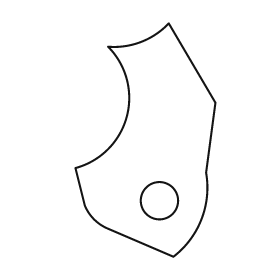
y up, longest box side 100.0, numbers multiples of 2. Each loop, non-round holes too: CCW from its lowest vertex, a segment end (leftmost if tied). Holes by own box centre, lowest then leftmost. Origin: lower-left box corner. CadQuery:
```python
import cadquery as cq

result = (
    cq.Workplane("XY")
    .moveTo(42.0, 0.0)
    .threePointArc((54.0, 16.0), (56.0, 36.0))
    .lineTo(60.0, 66.0)
    .lineTo(40.0, 100.0)
    .threePointArc((28.0, 92.0), (14.0, 90.0))
    .threePointArc((22.0, 60.0), (0.0, 38.0))
    .lineTo(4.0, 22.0)
    .threePointArc((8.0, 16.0), (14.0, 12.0))
    .close()
    .moveTo(36.0, 24.0)
    .circle(8.0)
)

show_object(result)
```